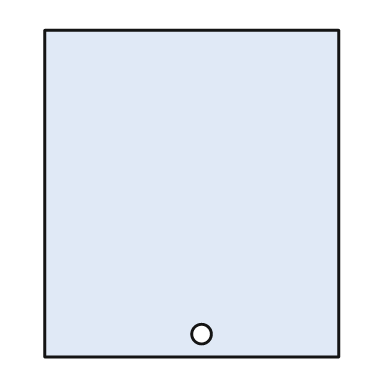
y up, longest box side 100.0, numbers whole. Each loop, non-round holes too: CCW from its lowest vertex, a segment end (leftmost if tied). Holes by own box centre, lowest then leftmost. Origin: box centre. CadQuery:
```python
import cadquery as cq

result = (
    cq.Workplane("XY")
    .moveTo(-45.0, -50.0)
    .lineTo(45.0, -50.0)
    .lineTo(45.0, 50.0)
    .lineTo(-45.0, 50.0)
    .close()
    .moveTo(3.0, -43.0)
    .circle(3.0)
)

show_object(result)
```